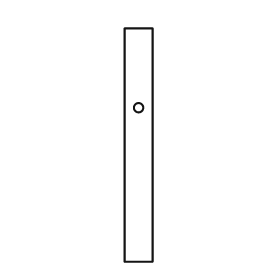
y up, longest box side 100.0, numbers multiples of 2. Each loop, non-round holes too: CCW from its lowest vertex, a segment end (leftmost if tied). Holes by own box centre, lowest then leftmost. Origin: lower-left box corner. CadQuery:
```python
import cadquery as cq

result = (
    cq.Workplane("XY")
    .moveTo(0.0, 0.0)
    .lineTo(12.0, 0.0)
    .lineTo(12.0, 100.0)
    .lineTo(0.0, 100.0)
    .close()
    .moveTo(6.0, 66.0)
    .circle(2.0)
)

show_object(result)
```